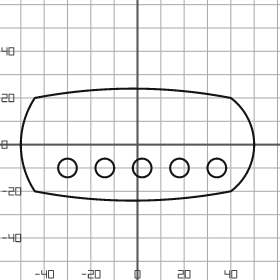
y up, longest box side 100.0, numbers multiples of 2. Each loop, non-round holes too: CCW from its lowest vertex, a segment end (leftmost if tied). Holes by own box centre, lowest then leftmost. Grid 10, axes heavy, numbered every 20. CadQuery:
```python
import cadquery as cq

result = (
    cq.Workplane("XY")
    .moveTo(-44.0, -20.0)
    .threePointArc((-2.0, -24.0), (40.0, -20.0))
    .threePointArc((50.0, 0.0), (40.0, 20.0))
    .threePointArc((-2.0, 24.0), (-44.0, 20.0))
    .threePointArc((-50.0, 0.0), (-44.0, -20.0))
    .close()
    .moveTo(-30.0, -10.0)
    .circle(4.0)
    .moveTo(-14.0, -10.0)
    .circle(4.0)
    .moveTo(2.0, -10.0)
    .circle(4.0)
    .moveTo(18.0, -10.0)
    .circle(4.0)
    .moveTo(34.0, -10.0)
    .circle(4.0)
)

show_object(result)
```